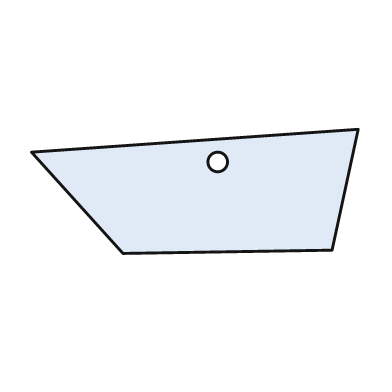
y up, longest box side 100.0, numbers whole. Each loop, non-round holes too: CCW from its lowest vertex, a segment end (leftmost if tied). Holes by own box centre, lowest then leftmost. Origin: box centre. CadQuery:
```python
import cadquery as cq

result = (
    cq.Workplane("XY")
    .moveTo(-22.0, -19.0)
    .lineTo(42.0, -18.0)
    .lineTo(50.0, 19.0)
    .lineTo(-50.0, 12.0)
    .close()
    .moveTo(7.0, 9.0)
    .circle(3.0)
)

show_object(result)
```